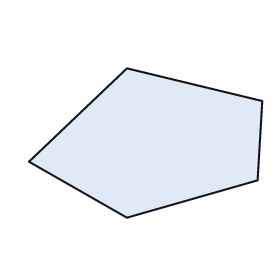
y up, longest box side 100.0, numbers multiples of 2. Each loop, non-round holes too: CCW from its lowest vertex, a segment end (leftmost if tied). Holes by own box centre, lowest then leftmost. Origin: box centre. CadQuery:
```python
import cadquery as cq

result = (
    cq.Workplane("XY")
    .moveTo(-8.0, -32.0)
    .lineTo(48.0, -16.0)
    .lineTo(50.0, 18.0)
    .lineTo(-8.0, 32.0)
    .lineTo(-50.0, -8.0)
    .close()
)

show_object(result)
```